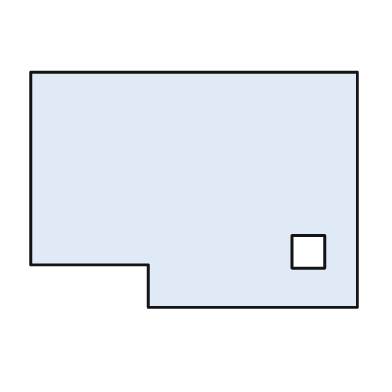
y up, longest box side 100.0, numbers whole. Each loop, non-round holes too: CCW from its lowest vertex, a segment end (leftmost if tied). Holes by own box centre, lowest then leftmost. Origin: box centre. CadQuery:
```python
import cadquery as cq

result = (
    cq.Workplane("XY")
    .moveTo(-14.0, -36.0)
    .lineTo(50.0, -36.0)
    .lineTo(50.0, 36.0)
    .lineTo(-50.0, 36.0)
    .lineTo(-50.0, -23.0)
    .lineTo(-14.0, -23.0)
    .close()
    .moveTo(30.0, -24.0)
    .lineTo(40.0, -24.0)
    .lineTo(40.0, -14.0)
    .lineTo(30.0, -14.0)
    .close()
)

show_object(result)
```